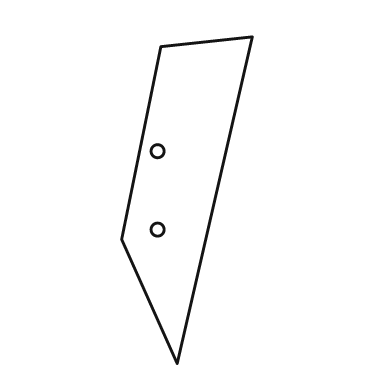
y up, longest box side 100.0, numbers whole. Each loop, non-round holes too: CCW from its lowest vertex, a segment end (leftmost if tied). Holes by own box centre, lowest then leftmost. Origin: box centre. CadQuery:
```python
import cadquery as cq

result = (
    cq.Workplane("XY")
    .moveTo(-3.0, -50.0)
    .lineTo(20.0, 50.0)
    .lineTo(-8.0, 47.0)
    .lineTo(-20.0, -12.0)
    .close()
    .moveTo(-9.0, -9.0)
    .circle(2.0)
    .moveTo(-9.0, 15.0)
    .circle(2.0)
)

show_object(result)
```